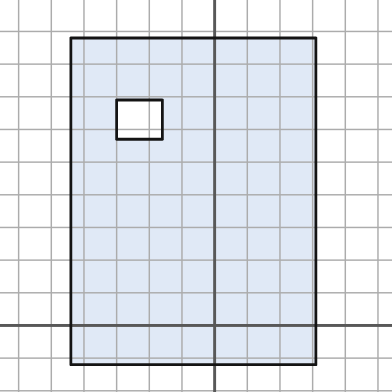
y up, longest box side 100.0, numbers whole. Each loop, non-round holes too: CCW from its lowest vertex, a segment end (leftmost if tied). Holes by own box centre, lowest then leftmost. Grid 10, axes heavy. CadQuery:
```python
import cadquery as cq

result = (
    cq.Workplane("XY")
    .moveTo(-44.0, -12.0)
    .lineTo(31.0, -12.0)
    .lineTo(31.0, 88.0)
    .lineTo(-44.0, 88.0)
    .close()
    .moveTo(-30.0, 57.0)
    .lineTo(-16.0, 57.0)
    .lineTo(-16.0, 69.0)
    .lineTo(-30.0, 69.0)
    .close()
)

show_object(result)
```